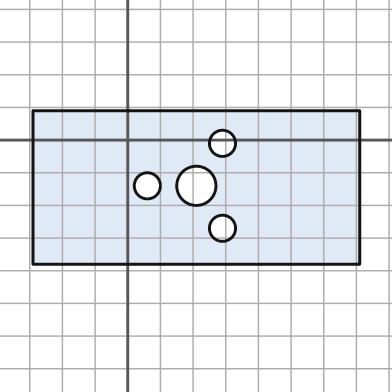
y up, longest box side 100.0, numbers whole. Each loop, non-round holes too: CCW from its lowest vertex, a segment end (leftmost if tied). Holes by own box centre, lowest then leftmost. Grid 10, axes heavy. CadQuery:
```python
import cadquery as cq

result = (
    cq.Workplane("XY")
    .moveTo(-29.0, -38.0)
    .lineTo(71.0, -38.0)
    .lineTo(71.0, 9.0)
    .lineTo(-29.0, 9.0)
    .close()
    .moveTo(29.0, -27.0)
    .circle(4.0)
    .moveTo(6.0, -14.0)
    .circle(4.0)
    .moveTo(21.0, -14.0)
    .circle(6.0)
    .moveTo(29.0, -1.0)
    .circle(4.0)
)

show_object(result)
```